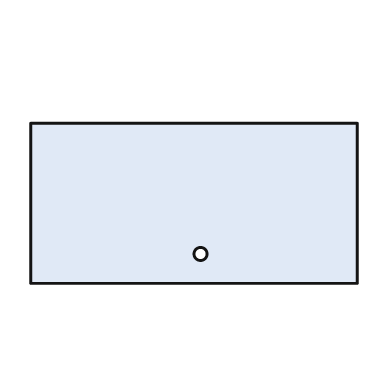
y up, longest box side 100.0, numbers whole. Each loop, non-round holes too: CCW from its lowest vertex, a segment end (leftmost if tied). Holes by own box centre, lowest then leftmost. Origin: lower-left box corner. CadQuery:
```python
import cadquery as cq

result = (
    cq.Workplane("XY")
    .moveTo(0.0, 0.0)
    .lineTo(100.0, 0.0)
    .lineTo(100.0, 49.0)
    .lineTo(0.0, 49.0)
    .close()
    .moveTo(52.0, 9.0)
    .circle(2.0)
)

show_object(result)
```